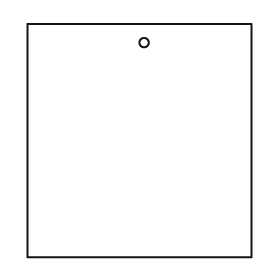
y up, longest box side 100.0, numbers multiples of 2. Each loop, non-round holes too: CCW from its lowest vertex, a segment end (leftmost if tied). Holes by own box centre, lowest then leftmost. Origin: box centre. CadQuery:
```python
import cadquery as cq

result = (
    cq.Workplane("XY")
    .moveTo(-48.0, -50.0)
    .lineTo(48.0, -50.0)
    .lineTo(48.0, 50.0)
    .lineTo(-48.0, 50.0)
    .close()
    .moveTo(2.0, 42.0)
    .circle(2.0)
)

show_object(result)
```